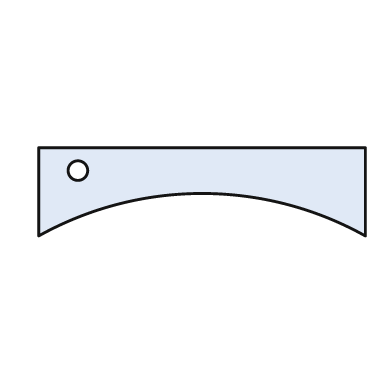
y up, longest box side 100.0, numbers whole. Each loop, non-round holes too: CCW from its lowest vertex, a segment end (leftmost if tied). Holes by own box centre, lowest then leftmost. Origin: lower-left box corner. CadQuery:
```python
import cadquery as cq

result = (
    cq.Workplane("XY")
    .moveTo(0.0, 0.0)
    .threePointArc((50.0, 13.0), (100.0, 0.0))
    .lineTo(100.0, 27.0)
    .lineTo(0.0, 27.0)
    .close()
    .moveTo(12.0, 20.0)
    .circle(3.0)
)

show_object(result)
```